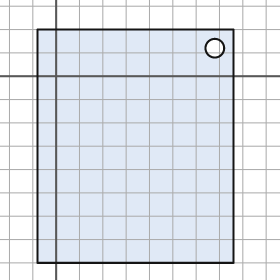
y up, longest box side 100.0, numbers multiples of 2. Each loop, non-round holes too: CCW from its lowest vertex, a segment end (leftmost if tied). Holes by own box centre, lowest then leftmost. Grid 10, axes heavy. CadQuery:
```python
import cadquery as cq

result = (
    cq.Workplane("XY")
    .moveTo(-8.0, -80.0)
    .lineTo(76.0, -80.0)
    .lineTo(76.0, 20.0)
    .lineTo(-8.0, 20.0)
    .close()
    .moveTo(68.0, 12.0)
    .circle(4.0)
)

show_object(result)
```